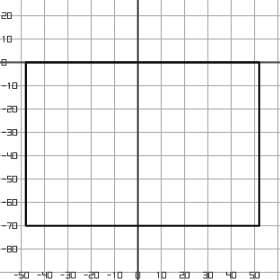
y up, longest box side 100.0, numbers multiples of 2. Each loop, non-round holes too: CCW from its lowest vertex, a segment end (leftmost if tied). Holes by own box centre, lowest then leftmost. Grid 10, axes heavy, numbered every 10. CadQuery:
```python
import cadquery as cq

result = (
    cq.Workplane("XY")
    .moveTo(-48.0, -70.0)
    .lineTo(52.0, -70.0)
    .lineTo(52.0, 0.0)
    .lineTo(-48.0, 0.0)
    .close()
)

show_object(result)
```